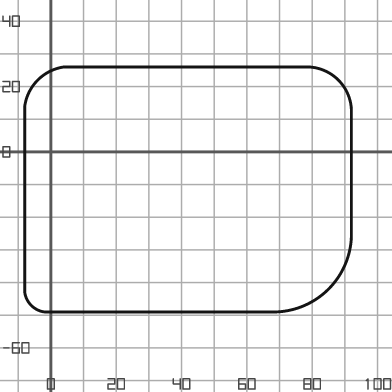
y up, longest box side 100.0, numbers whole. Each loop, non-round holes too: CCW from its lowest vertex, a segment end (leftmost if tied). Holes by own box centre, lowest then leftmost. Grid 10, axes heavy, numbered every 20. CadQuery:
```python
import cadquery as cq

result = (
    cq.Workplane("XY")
    .moveTo(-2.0, -49.0)
    .lineTo(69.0, -49.0)
    .threePointArc((85.0, -42.0), (92.0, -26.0))
    .lineTo(92.0, 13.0)
    .threePointArc((88.0, 22.0), (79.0, 26.0))
    .lineTo(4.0, 26.0)
    .threePointArc((-4.0, 22.0), (-8.0, 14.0))
    .lineTo(-8.0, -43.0)
    .threePointArc((-6.0, -47.0), (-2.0, -49.0))
    .close()
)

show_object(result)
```